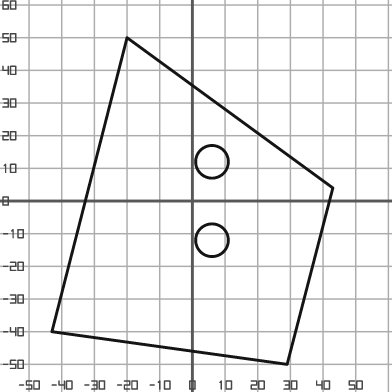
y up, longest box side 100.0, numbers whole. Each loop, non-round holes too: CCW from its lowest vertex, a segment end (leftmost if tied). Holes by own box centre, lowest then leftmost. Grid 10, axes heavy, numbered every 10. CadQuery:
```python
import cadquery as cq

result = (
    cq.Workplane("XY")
    .moveTo(29.0, -50.0)
    .lineTo(43.0, 4.0)
    .lineTo(-20.0, 50.0)
    .lineTo(-43.0, -40.0)
    .close()
    .moveTo(6.0, -12.0)
    .circle(5.0)
    .moveTo(6.0, 12.0)
    .circle(5.0)
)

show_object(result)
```